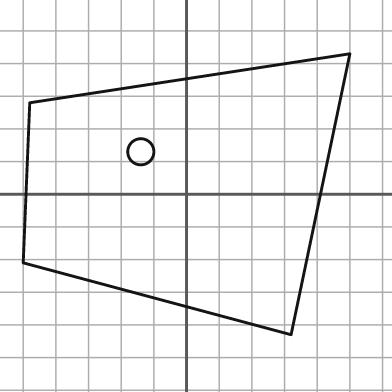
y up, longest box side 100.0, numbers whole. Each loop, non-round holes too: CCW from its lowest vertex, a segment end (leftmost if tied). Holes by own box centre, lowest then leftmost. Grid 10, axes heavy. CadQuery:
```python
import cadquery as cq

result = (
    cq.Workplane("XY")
    .moveTo(32.0, -43.0)
    .lineTo(50.0, 43.0)
    .lineTo(-48.0, 28.0)
    .lineTo(-50.0, -21.0)
    .close()
    .moveTo(-14.0, 13.0)
    .circle(4.0)
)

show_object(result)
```